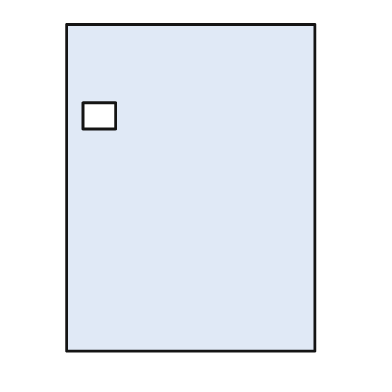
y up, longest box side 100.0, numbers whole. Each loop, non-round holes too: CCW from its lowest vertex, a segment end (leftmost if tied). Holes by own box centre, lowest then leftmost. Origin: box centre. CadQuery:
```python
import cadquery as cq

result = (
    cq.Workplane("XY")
    .moveTo(-38.0, -50.0)
    .lineTo(38.0, -50.0)
    .lineTo(38.0, 50.0)
    .lineTo(-38.0, 50.0)
    .close()
    .moveTo(-33.0, 18.0)
    .lineTo(-23.0, 18.0)
    .lineTo(-23.0, 26.0)
    .lineTo(-33.0, 26.0)
    .close()
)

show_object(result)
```